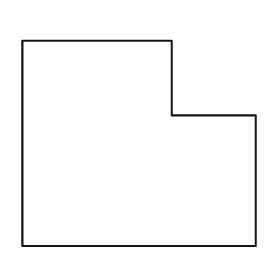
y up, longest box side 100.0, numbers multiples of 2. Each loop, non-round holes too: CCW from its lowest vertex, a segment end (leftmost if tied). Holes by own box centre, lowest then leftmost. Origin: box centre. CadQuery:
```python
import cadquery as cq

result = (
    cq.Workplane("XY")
    .moveTo(-50.0, -44.0)
    .lineTo(50.0, -44.0)
    .lineTo(50.0, 12.0)
    .lineTo(14.0, 12.0)
    .lineTo(14.0, 44.0)
    .lineTo(-50.0, 44.0)
    .close()
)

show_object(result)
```